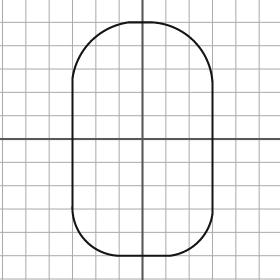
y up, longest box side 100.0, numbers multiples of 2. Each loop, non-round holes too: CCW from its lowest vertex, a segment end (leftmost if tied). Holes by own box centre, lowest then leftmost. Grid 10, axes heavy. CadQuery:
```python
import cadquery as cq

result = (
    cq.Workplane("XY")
    .moveTo(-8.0, -50.0)
    .lineTo(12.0, -50.0)
    .threePointArc((24.0, -44.0), (30.0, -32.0))
    .lineTo(30.0, 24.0)
    .threePointArc((22.0, 42.0), (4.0, 50.0))
    .lineTo(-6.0, 50.0)
    .threePointArc((-22.0, 42.0), (-30.0, 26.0))
    .lineTo(-30.0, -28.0)
    .threePointArc((-24.0, -44.0), (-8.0, -50.0))
    .close()
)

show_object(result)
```